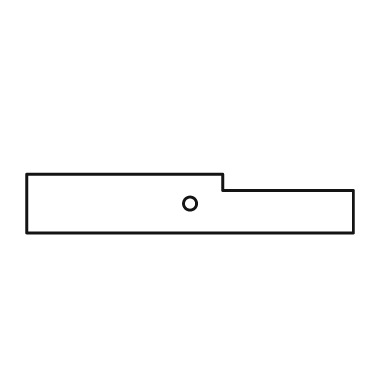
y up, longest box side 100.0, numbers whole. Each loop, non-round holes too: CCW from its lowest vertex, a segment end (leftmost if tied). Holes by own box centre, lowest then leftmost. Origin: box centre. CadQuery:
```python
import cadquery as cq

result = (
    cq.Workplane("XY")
    .moveTo(-50.0, -9.0)
    .lineTo(50.0, -9.0)
    .lineTo(50.0, 4.0)
    .lineTo(10.0, 4.0)
    .lineTo(10.0, 9.0)
    .lineTo(-50.0, 9.0)
    .close()
    .moveTo(0.0, 0.0)
    .circle(2.0)
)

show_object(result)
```